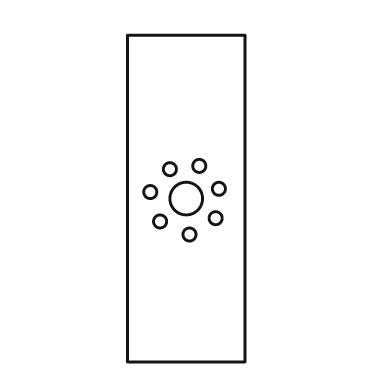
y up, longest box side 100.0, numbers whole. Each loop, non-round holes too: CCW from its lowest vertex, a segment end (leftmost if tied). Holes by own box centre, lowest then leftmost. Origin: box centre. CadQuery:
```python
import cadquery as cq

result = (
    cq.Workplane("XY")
    .moveTo(-18.0, -50.0)
    .lineTo(18.0, -50.0)
    .lineTo(18.0, 50.0)
    .lineTo(-18.0, 50.0)
    .close()
    .moveTo(1.0, -11.0)
    .circle(2.0)
    .moveTo(-8.0, -7.0)
    .circle(2.0)
    .moveTo(9.0, -6.0)
    .circle(2.0)
    .moveTo(0.0, 0.0)
    .circle(5.0)
    .moveTo(-11.0, 2.0)
    .circle(2.0)
    .moveTo(10.0, 3.0)
    .circle(2.0)
    .moveTo(-5.0, 9.0)
    .circle(2.0)
    .moveTo(4.0, 10.0)
    .circle(2.0)
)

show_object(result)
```